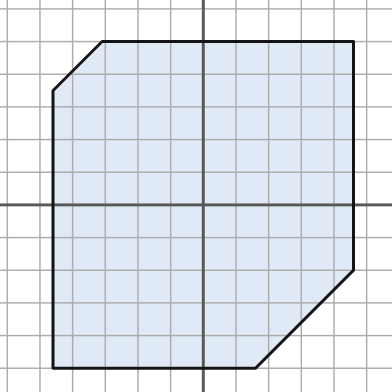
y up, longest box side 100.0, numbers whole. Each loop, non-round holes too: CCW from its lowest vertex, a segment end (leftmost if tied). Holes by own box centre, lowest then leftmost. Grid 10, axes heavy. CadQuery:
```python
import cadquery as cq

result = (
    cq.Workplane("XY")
    .moveTo(-46.0, -50.0)
    .lineTo(16.0, -50.0)
    .lineTo(46.0, -20.0)
    .lineTo(46.0, 50.0)
    .lineTo(-31.0, 50.0)
    .lineTo(-46.0, 35.0)
    .close()
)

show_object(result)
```